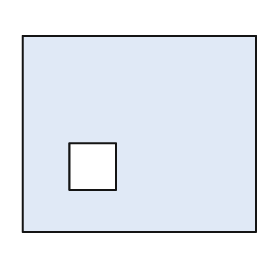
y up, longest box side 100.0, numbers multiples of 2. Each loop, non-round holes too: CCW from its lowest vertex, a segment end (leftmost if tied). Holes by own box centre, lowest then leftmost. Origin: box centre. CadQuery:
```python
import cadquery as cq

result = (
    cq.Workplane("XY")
    .moveTo(-50.0, -42.0)
    .lineTo(50.0, -42.0)
    .lineTo(50.0, 42.0)
    .lineTo(-50.0, 42.0)
    .close()
    .moveTo(-30.0, -24.0)
    .lineTo(-10.0, -24.0)
    .lineTo(-10.0, -4.0)
    .lineTo(-30.0, -4.0)
    .close()
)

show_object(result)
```